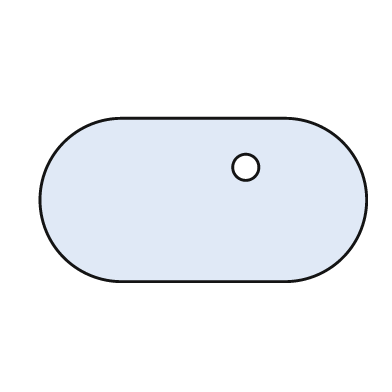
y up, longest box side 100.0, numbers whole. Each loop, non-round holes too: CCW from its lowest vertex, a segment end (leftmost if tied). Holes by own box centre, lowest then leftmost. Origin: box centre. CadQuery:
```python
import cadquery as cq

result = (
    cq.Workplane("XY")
    .moveTo(-25.0, -25.0)
    .lineTo(25.0, -25.0)
    .threePointArc((50.0, 0.0), (25.0, 25.0))
    .lineTo(-25.0, 25.0)
    .threePointArc((-50.0, 0.0), (-25.0, -25.0))
    .close()
    .moveTo(13.0, 10.0)
    .circle(4.0)
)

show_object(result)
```